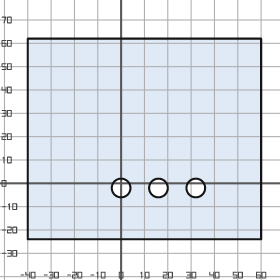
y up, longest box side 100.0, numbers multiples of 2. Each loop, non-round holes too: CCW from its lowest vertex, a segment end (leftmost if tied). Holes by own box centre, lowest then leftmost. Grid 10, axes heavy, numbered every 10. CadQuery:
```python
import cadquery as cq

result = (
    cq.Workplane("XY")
    .moveTo(-40.0, -24.0)
    .lineTo(60.0, -24.0)
    .lineTo(60.0, 62.0)
    .lineTo(-40.0, 62.0)
    .close()
    .moveTo(0.0, -2.0)
    .circle(4.0)
    .moveTo(16.0, -2.0)
    .circle(4.0)
    .moveTo(32.0, -2.0)
    .circle(4.0)
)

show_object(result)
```